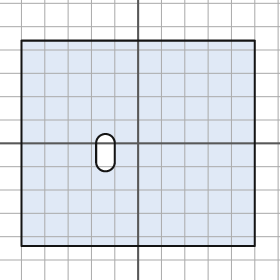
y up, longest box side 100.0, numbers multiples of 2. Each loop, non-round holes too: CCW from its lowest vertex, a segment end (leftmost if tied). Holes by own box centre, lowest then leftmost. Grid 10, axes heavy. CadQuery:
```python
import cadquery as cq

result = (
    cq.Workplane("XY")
    .moveTo(-50.0, -44.0)
    .lineTo(50.0, -44.0)
    .lineTo(50.0, 44.0)
    .lineTo(-50.0, 44.0)
    .close()
    .moveTo(-18.0, -8.0)
    .threePointArc((-14.0, -12.0), (-10.0, -8.0))
    .lineTo(-10.0, 0.0)
    .threePointArc((-14.0, 4.0), (-18.0, 0.0))
    .close()
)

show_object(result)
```